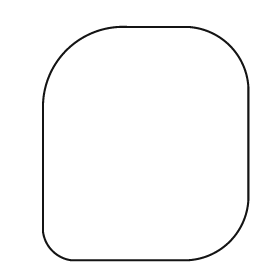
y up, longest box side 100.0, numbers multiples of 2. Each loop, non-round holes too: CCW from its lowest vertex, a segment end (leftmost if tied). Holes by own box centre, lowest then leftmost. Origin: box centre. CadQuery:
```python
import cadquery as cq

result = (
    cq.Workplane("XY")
    .moveTo(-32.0, -50.0)
    .lineTo(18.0, -50.0)
    .threePointArc((36.0, -42.0), (44.0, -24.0))
    .lineTo(44.0, 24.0)
    .threePointArc((36.0, 42.0), (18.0, 50.0))
    .lineTo(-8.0, 50.0)
    .threePointArc((-34.0, 40.0), (-44.0, 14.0))
    .lineTo(-44.0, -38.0)
    .threePointArc((-40.0, -46.0), (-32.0, -50.0))
    .close()
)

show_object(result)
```